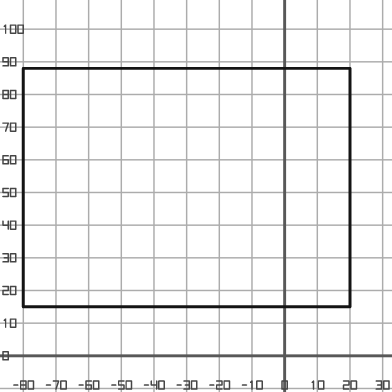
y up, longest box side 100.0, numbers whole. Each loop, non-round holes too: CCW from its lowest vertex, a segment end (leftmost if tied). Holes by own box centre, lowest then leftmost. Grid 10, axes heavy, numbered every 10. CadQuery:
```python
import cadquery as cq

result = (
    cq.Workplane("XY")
    .moveTo(-80.0, 15.0)
    .lineTo(20.0, 15.0)
    .lineTo(20.0, 88.0)
    .lineTo(-80.0, 88.0)
    .close()
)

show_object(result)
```